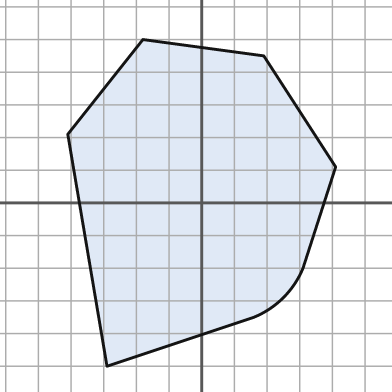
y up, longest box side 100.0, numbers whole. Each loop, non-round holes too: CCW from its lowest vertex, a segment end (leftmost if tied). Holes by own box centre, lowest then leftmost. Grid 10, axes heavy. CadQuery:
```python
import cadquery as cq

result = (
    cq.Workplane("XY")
    .moveTo(-29.0, -50.0)
    .lineTo(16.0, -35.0)
    .threePointArc((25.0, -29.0), (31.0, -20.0))
    .lineTo(41.0, 11.0)
    .lineTo(19.0, 45.0)
    .lineTo(-18.0, 50.0)
    .lineTo(-41.0, 21.0)
    .close()
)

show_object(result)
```